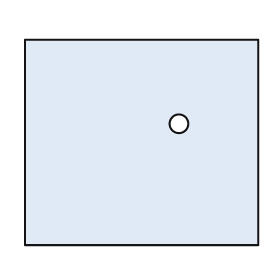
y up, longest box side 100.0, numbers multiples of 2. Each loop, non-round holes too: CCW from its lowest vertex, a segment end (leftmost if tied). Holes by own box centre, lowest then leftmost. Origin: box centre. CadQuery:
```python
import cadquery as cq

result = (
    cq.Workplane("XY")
    .moveTo(-50.0, -44.0)
    .lineTo(50.0, -44.0)
    .lineTo(50.0, 44.0)
    .lineTo(-50.0, 44.0)
    .close()
    .moveTo(16.0, 8.0)
    .circle(4.0)
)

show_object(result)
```